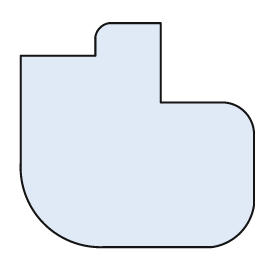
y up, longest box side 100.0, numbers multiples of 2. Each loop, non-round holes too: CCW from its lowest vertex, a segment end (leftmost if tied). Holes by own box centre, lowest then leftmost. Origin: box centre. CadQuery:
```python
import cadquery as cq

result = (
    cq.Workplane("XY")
    .moveTo(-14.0, -48.0)
    .lineTo(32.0, -48.0)
    .threePointArc((44.0, -42.0), (50.0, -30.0))
    .lineTo(50.0, 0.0)
    .threePointArc((46.0, 10.0), (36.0, 14.0))
    .lineTo(10.0, 14.0)
    .lineTo(10.0, 48.0)
    .lineTo(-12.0, 48.0)
    .threePointArc((-16.0, 46.0), (-18.0, 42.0))
    .lineTo(-18.0, 34.0)
    .lineTo(-50.0, 34.0)
    .lineTo(-50.0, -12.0)
    .threePointArc((-40.0, -38.0), (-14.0, -48.0))
    .close()
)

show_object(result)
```